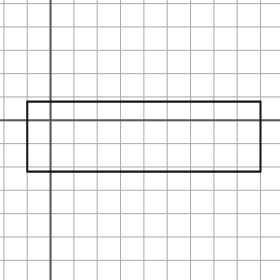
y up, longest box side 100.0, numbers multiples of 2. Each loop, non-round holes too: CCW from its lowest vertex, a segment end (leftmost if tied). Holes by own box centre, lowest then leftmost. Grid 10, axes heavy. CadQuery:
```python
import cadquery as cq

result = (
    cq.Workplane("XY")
    .moveTo(-10.0, -22.0)
    .lineTo(90.0, -22.0)
    .lineTo(90.0, 8.0)
    .lineTo(-10.0, 8.0)
    .close()
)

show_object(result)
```